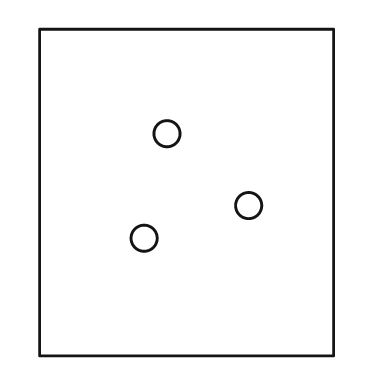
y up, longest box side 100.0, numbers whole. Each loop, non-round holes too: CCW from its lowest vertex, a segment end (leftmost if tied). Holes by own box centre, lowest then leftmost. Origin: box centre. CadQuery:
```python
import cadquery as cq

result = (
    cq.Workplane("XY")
    .moveTo(-45.0, -50.0)
    .lineTo(45.0, -50.0)
    .lineTo(45.0, 50.0)
    .lineTo(-45.0, 50.0)
    .close()
    .moveTo(-13.0, -14.0)
    .circle(4.0)
    .moveTo(19.0, -4.0)
    .circle(4.0)
    .moveTo(-6.0, 18.0)
    .circle(4.0)
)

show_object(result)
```